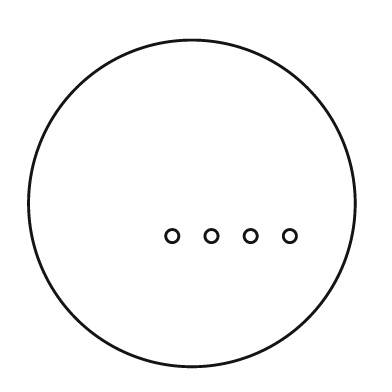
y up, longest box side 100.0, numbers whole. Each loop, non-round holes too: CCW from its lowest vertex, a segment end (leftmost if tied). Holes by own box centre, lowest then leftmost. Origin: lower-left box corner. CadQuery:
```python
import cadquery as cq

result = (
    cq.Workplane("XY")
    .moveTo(50.0, 50.0)
    .circle(50.0)
    .moveTo(44.0, 40.0)
    .circle(2.0)
    .moveTo(56.0, 40.0)
    .circle(2.0)
    .moveTo(68.0, 40.0)
    .circle(2.0)
    .moveTo(80.0, 40.0)
    .circle(2.0)
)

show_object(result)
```